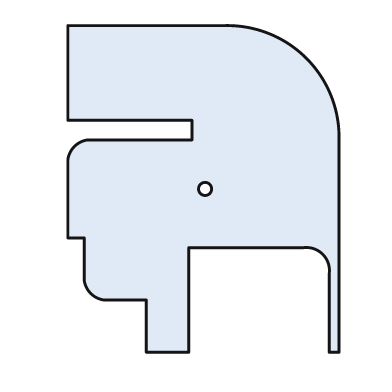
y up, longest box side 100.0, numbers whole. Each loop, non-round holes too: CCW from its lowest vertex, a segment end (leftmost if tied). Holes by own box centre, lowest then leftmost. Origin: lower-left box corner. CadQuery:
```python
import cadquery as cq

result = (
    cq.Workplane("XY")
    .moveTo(24.0, 0.0)
    .lineTo(37.0, 0.0)
    .lineTo(37.0, 32.0)
    .lineTo(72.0, 32.0)
    .threePointArc((78.0, 30.0), (80.0, 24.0))
    .lineTo(80.0, 0.0)
    .lineTo(83.0, 0.0)
    .lineTo(83.0, 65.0)
    .threePointArc((73.0, 90.0), (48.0, 100.0))
    .lineTo(0.0, 100.0)
    .lineTo(0.0, 71.0)
    .lineTo(38.0, 71.0)
    .lineTo(38.0, 65.0)
    .lineTo(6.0, 65.0)
    .threePointArc((2.0, 63.0), (0.0, 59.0))
    .lineTo(0.0, 35.0)
    .lineTo(5.0, 35.0)
    .lineTo(5.0, 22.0)
    .threePointArc((7.0, 18.0), (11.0, 16.0))
    .lineTo(24.0, 16.0)
    .close()
    .moveTo(42.0, 50.0)
    .circle(2.0)
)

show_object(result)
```